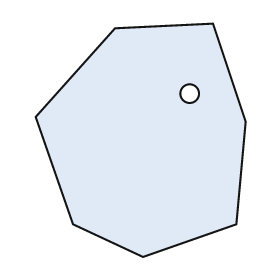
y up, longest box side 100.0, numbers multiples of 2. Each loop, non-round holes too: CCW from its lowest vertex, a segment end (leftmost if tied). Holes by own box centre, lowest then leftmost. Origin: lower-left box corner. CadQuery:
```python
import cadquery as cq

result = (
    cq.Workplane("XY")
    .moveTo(46.0, 0.0)
    .lineTo(86.0, 14.0)
    .lineTo(90.0, 58.0)
    .lineTo(76.0, 100.0)
    .lineTo(34.0, 98.0)
    .lineTo(0.0, 60.0)
    .lineTo(16.0, 14.0)
    .close()
    .moveTo(66.0, 70.0)
    .circle(4.0)
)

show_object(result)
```